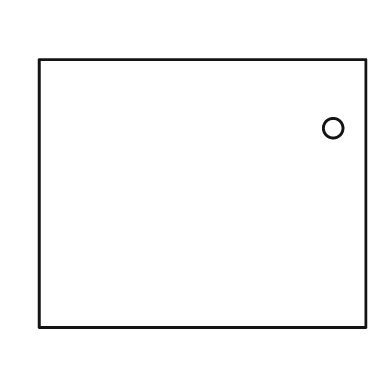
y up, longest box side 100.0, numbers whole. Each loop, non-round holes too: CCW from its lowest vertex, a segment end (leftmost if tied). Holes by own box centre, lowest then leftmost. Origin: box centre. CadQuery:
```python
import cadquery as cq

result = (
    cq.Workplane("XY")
    .moveTo(-50.0, -41.0)
    .lineTo(50.0, -41.0)
    .lineTo(50.0, 41.0)
    .lineTo(-50.0, 41.0)
    .close()
    .moveTo(40.0, 20.0)
    .circle(3.0)
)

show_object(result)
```